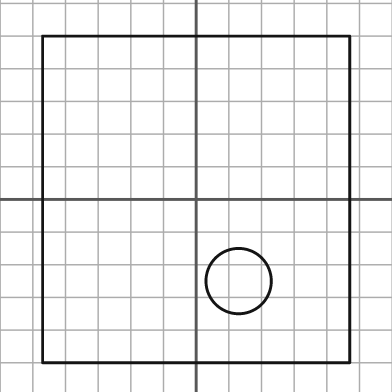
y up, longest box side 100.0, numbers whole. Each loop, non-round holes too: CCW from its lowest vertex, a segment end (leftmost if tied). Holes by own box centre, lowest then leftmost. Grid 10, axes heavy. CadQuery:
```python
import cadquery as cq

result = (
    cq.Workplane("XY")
    .moveTo(-47.0, -50.0)
    .lineTo(47.0, -50.0)
    .lineTo(47.0, 50.0)
    .lineTo(-47.0, 50.0)
    .close()
    .moveTo(13.0, -25.0)
    .circle(10.0)
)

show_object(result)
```